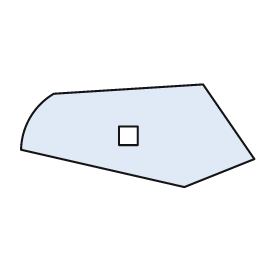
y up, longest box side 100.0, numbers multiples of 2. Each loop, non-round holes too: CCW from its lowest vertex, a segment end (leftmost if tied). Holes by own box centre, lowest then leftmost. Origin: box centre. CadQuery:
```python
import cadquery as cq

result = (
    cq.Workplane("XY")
    .moveTo(20.0, -22.0)
    .lineTo(50.0, -10.0)
    .lineTo(28.0, 22.0)
    .lineTo(-36.0, 18.0)
    .threePointArc((-46.0, 8.0), (-50.0, -6.0))
    .close()
    .moveTo(-8.0, -4.0)
    .lineTo(0.0, -4.0)
    .lineTo(0.0, 4.0)
    .lineTo(-8.0, 4.0)
    .close()
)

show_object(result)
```